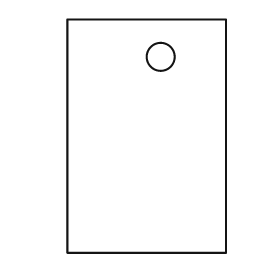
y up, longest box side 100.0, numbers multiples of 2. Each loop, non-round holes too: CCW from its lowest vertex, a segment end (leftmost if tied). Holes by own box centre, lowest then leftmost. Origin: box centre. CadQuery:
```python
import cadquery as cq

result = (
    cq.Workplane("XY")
    .moveTo(-34.0, -50.0)
    .lineTo(34.0, -50.0)
    .lineTo(34.0, 50.0)
    .lineTo(-34.0, 50.0)
    .close()
    .moveTo(6.0, 34.0)
    .circle(6.0)
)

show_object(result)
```